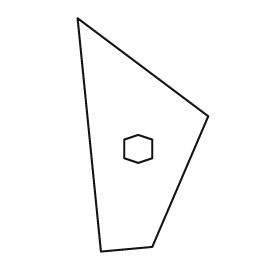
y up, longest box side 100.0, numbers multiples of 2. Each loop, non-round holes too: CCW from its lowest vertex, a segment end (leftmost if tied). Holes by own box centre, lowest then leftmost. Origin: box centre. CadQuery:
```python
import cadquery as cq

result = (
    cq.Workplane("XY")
    .moveTo(-18.0, -50.0)
    .lineTo(4.0, -48.0)
    .lineTo(28.0, 8.0)
    .lineTo(-28.0, 50.0)
    .close()
    .moveTo(-2.0, -12.0)
    .lineTo(4.0, -10.0)
    .lineTo(4.0, -2.0)
    .lineTo(-2.0, 0.0)
    .lineTo(-8.0, -2.0)
    .lineTo(-8.0, -10.0)
    .close()
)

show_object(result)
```